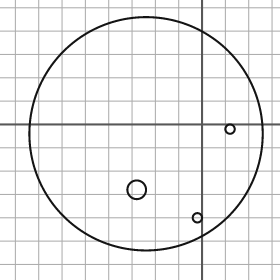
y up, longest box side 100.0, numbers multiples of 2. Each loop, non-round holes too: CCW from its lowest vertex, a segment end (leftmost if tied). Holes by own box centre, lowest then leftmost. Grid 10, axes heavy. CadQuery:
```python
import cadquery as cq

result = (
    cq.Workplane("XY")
    .moveTo(-24.0, -4.0)
    .circle(50.0)
    .moveTo(-2.0, -40.0)
    .circle(2.0)
    .moveTo(-28.0, -28.0)
    .circle(4.0)
    .moveTo(12.0, -2.0)
    .circle(2.0)
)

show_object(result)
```